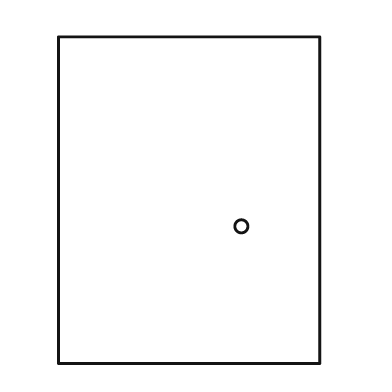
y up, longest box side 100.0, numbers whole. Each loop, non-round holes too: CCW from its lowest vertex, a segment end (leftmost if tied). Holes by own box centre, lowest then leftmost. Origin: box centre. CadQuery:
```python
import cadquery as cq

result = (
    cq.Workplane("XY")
    .moveTo(-40.0, -50.0)
    .lineTo(40.0, -50.0)
    .lineTo(40.0, 50.0)
    .lineTo(-40.0, 50.0)
    .close()
    .moveTo(16.0, -8.0)
    .circle(2.0)
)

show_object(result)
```